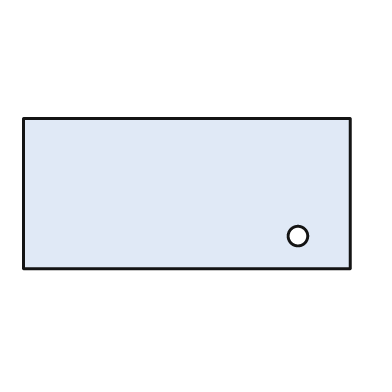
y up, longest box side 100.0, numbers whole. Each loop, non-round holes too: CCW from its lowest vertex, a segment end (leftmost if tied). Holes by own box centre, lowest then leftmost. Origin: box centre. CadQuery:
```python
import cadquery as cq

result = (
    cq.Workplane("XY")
    .moveTo(-50.0, -23.0)
    .lineTo(50.0, -23.0)
    .lineTo(50.0, 23.0)
    .lineTo(-50.0, 23.0)
    .close()
    .moveTo(34.0, -13.0)
    .circle(3.0)
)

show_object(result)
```